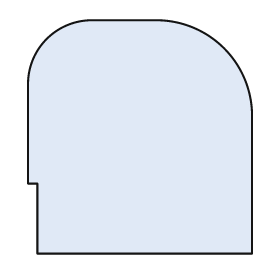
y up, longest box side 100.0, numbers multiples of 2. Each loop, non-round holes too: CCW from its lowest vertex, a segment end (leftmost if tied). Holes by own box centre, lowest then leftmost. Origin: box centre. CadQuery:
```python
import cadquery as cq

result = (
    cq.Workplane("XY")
    .moveTo(-44.0, -50.0)
    .lineTo(48.0, -50.0)
    .lineTo(48.0, 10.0)
    .threePointArc((36.0, 38.0), (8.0, 50.0))
    .lineTo(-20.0, 50.0)
    .threePointArc((-40.0, 42.0), (-48.0, 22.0))
    .lineTo(-48.0, -20.0)
    .lineTo(-44.0, -20.0)
    .close()
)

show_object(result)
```